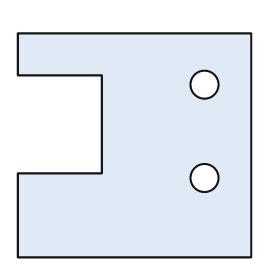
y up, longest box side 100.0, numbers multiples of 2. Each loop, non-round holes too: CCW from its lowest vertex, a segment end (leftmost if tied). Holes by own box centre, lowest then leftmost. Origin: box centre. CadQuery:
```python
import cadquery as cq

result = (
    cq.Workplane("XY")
    .moveTo(-50.0, -48.0)
    .lineTo(50.0, -48.0)
    .lineTo(50.0, 48.0)
    .lineTo(-50.0, 48.0)
    .lineTo(-50.0, 30.0)
    .lineTo(-14.0, 30.0)
    .lineTo(-14.0, -12.0)
    .lineTo(-50.0, -12.0)
    .close()
    .moveTo(30.0, -14.0)
    .circle(6.0)
    .moveTo(30.0, 26.0)
    .circle(6.0)
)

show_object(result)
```